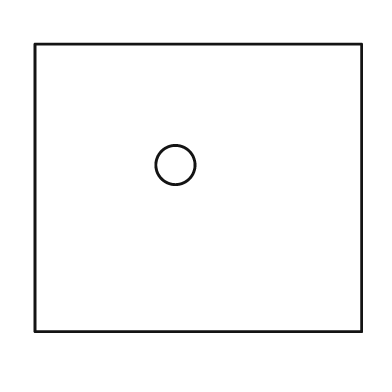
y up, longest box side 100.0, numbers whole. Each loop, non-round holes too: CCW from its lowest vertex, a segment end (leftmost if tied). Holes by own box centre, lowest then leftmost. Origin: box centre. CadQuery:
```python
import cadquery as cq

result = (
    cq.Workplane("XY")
    .moveTo(-50.0, -44.0)
    .lineTo(50.0, -44.0)
    .lineTo(50.0, 44.0)
    .lineTo(-50.0, 44.0)
    .close()
    .moveTo(-7.0, 7.0)
    .circle(6.0)
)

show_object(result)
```